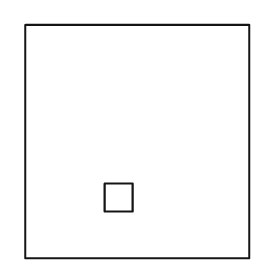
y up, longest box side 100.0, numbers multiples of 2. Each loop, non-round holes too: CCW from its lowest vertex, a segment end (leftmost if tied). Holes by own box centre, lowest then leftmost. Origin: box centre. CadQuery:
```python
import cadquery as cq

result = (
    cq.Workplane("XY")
    .moveTo(-48.0, -50.0)
    .lineTo(48.0, -50.0)
    .lineTo(48.0, 50.0)
    .lineTo(-48.0, 50.0)
    .close()
    .moveTo(-14.0, -30.0)
    .lineTo(-2.0, -30.0)
    .lineTo(-2.0, -18.0)
    .lineTo(-14.0, -18.0)
    .close()
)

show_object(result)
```